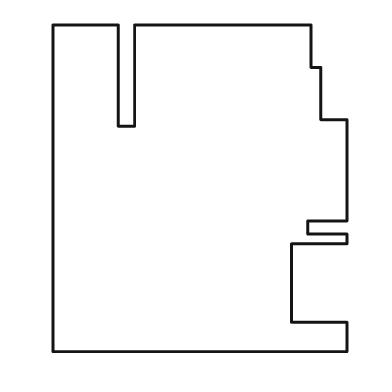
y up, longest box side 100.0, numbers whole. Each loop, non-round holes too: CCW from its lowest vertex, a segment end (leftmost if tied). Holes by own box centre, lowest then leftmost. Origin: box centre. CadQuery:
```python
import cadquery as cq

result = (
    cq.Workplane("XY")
    .moveTo(-45.0, -50.0)
    .lineTo(45.0, -50.0)
    .lineTo(45.0, -41.0)
    .lineTo(28.0, -41.0)
    .lineTo(28.0, -17.0)
    .lineTo(45.0, -17.0)
    .lineTo(45.0, -14.0)
    .lineTo(33.0, -14.0)
    .lineTo(33.0, -10.0)
    .lineTo(45.0, -10.0)
    .lineTo(45.0, 21.0)
    .lineTo(37.0, 21.0)
    .lineTo(37.0, 37.0)
    .lineTo(34.0, 37.0)
    .lineTo(34.0, 50.0)
    .lineTo(-20.0, 50.0)
    .lineTo(-20.0, 19.0)
    .lineTo(-25.0, 19.0)
    .lineTo(-25.0, 50.0)
    .lineTo(-45.0, 50.0)
    .close()
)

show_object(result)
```